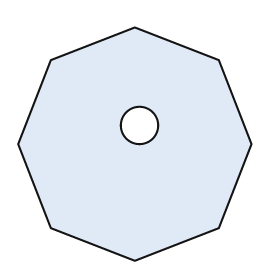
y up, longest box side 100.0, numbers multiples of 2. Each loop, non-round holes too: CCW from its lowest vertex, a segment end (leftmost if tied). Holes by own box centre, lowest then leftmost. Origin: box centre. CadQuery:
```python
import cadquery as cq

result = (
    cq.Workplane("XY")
    .moveTo(0.0, -50.0)
    .lineTo(36.0, -36.0)
    .lineTo(50.0, 0.0)
    .lineTo(36.0, 36.0)
    .lineTo(0.0, 50.0)
    .lineTo(-36.0, 36.0)
    .lineTo(-50.0, 0.0)
    .lineTo(-36.0, -36.0)
    .close()
    .moveTo(2.0, 8.0)
    .circle(8.0)
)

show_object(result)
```